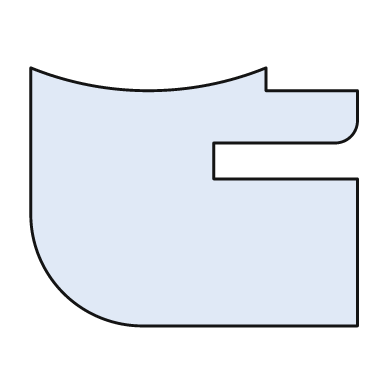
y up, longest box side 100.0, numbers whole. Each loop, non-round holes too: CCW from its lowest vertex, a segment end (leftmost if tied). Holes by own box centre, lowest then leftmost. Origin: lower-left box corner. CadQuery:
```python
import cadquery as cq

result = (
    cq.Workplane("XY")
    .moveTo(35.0, 0.0)
    .lineTo(100.0, 0.0)
    .lineTo(100.0, 45.0)
    .lineTo(56.0, 45.0)
    .lineTo(56.0, 56.0)
    .lineTo(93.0, 56.0)
    .threePointArc((98.0, 58.0), (100.0, 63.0))
    .lineTo(100.0, 72.0)
    .lineTo(72.0, 72.0)
    .lineTo(72.0, 79.0)
    .threePointArc((36.0, 72.0), (0.0, 79.0))
    .lineTo(0.0, 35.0)
    .threePointArc((10.0, 10.0), (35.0, 0.0))
    .close()
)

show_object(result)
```